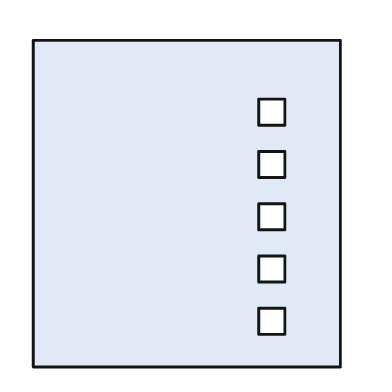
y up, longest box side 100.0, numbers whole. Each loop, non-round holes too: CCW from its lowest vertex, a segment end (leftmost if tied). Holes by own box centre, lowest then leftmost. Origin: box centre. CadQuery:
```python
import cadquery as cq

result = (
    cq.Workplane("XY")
    .moveTo(-47.0, -50.0)
    .lineTo(47.0, -50.0)
    .lineTo(47.0, 50.0)
    .lineTo(-47.0, 50.0)
    .close()
    .moveTo(22.0, -40.0)
    .lineTo(30.0, -40.0)
    .lineTo(30.0, -32.0)
    .lineTo(22.0, -32.0)
    .close()
    .moveTo(22.0, -24.0)
    .lineTo(30.0, -24.0)
    .lineTo(30.0, -16.0)
    .lineTo(22.0, -16.0)
    .close()
    .moveTo(22.0, -8.0)
    .lineTo(30.0, -8.0)
    .lineTo(30.0, 0.0)
    .lineTo(22.0, 0.0)
    .close()
    .moveTo(22.0, 8.0)
    .lineTo(30.0, 8.0)
    .lineTo(30.0, 16.0)
    .lineTo(22.0, 16.0)
    .close()
    .moveTo(22.0, 24.0)
    .lineTo(30.0, 24.0)
    .lineTo(30.0, 32.0)
    .lineTo(22.0, 32.0)
    .close()
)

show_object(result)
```